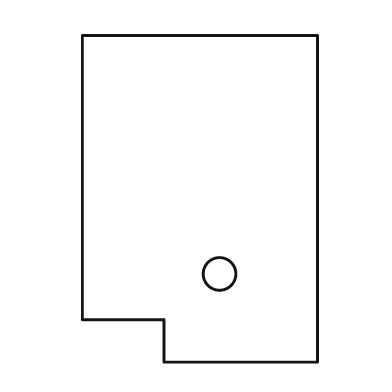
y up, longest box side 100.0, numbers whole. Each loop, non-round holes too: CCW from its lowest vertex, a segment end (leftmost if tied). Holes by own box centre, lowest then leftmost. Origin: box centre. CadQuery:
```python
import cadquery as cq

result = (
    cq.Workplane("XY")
    .moveTo(-11.0, -50.0)
    .lineTo(36.0, -50.0)
    .lineTo(36.0, 50.0)
    .lineTo(-36.0, 50.0)
    .lineTo(-36.0, -37.0)
    .lineTo(-11.0, -37.0)
    .close()
    .moveTo(6.0, -23.0)
    .circle(5.0)
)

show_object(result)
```